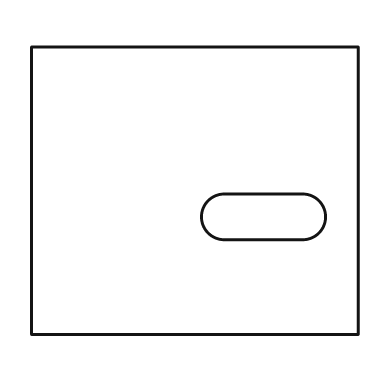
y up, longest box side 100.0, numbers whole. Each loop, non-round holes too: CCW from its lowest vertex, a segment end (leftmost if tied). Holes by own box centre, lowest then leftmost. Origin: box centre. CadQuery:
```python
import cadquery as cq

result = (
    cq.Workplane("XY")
    .moveTo(-50.0, -44.0)
    .lineTo(50.0, -44.0)
    .lineTo(50.0, 44.0)
    .lineTo(-50.0, 44.0)
    .close()
    .moveTo(9.0, -15.0)
    .lineTo(33.0, -15.0)
    .threePointArc((40.0, -8.0), (33.0, -1.0))
    .lineTo(9.0, -1.0)
    .threePointArc((2.0, -8.0), (9.0, -15.0))
    .close()
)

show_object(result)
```